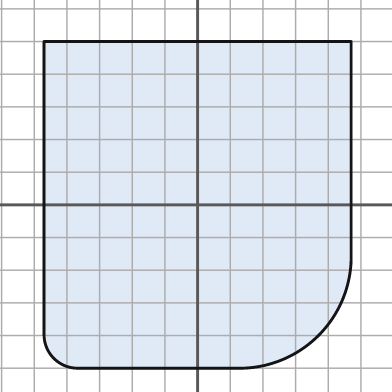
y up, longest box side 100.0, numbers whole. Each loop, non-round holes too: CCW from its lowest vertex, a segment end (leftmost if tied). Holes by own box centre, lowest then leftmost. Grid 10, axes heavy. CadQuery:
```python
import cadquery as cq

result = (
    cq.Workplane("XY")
    .moveTo(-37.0, -50.0)
    .lineTo(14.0, -50.0)
    .threePointArc((37.0, -40.0), (47.0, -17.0))
    .lineTo(47.0, 50.0)
    .lineTo(-47.0, 50.0)
    .lineTo(-47.0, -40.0)
    .threePointArc((-44.0, -47.0), (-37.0, -50.0))
    .close()
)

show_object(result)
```